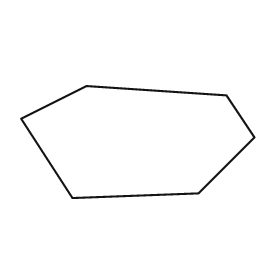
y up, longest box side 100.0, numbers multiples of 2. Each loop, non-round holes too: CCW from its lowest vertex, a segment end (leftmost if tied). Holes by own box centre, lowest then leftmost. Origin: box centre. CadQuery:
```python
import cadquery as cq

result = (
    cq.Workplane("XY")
    .moveTo(-28.0, -24.0)
    .lineTo(26.0, -22.0)
    .lineTo(50.0, 2.0)
    .lineTo(38.0, 20.0)
    .lineTo(-22.0, 24.0)
    .lineTo(-50.0, 10.0)
    .close()
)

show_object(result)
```